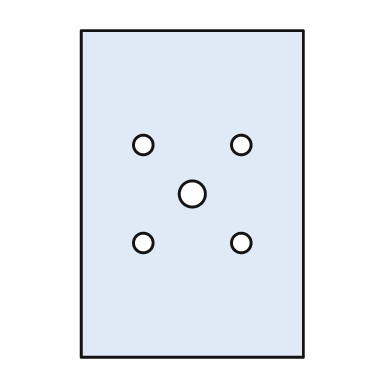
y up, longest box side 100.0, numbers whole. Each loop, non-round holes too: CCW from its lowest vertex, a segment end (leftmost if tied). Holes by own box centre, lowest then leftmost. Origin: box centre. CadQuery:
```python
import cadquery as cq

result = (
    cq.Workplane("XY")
    .moveTo(-34.0, -50.0)
    .lineTo(34.0, -50.0)
    .lineTo(34.0, 50.0)
    .lineTo(-34.0, 50.0)
    .close()
    .moveTo(-15.0, -15.0)
    .circle(3.0)
    .moveTo(15.0, -15.0)
    .circle(3.0)
    .moveTo(0.0, 0.0)
    .circle(4.0)
    .moveTo(-15.0, 15.0)
    .circle(3.0)
    .moveTo(15.0, 15.0)
    .circle(3.0)
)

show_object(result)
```